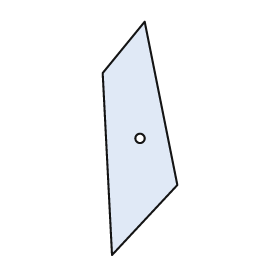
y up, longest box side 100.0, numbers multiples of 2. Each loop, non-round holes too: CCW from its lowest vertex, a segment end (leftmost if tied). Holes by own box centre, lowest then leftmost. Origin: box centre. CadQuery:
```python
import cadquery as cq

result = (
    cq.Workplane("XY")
    .moveTo(-12.0, -50.0)
    .lineTo(16.0, -20.0)
    .lineTo(2.0, 50.0)
    .lineTo(-16.0, 28.0)
    .close()
    .moveTo(0.0, 0.0)
    .circle(2.0)
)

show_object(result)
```